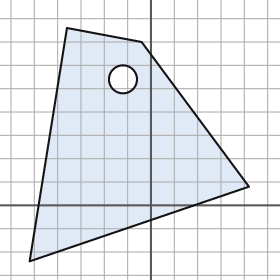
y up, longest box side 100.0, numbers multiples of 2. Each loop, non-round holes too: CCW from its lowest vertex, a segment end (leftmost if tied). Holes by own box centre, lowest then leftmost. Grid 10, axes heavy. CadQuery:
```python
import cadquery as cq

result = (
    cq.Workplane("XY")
    .moveTo(-52.0, -24.0)
    .lineTo(42.0, 8.0)
    .lineTo(-4.0, 70.0)
    .lineTo(-36.0, 76.0)
    .close()
    .moveTo(-12.0, 54.0)
    .circle(6.0)
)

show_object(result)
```